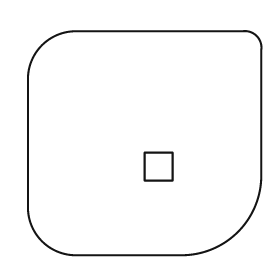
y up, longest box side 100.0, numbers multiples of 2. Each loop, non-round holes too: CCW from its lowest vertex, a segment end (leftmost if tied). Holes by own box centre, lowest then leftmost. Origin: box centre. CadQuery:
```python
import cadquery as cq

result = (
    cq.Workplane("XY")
    .moveTo(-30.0, -48.0)
    .lineTo(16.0, -48.0)
    .threePointArc((40.0, -38.0), (50.0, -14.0))
    .lineTo(50.0, 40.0)
    .threePointArc((48.0, 46.0), (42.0, 48.0))
    .lineTo(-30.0, 48.0)
    .threePointArc((-44.0, 42.0), (-50.0, 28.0))
    .lineTo(-50.0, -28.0)
    .threePointArc((-44.0, -42.0), (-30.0, -48.0))
    .close()
    .moveTo(0.0, -16.0)
    .lineTo(12.0, -16.0)
    .lineTo(12.0, -4.0)
    .lineTo(0.0, -4.0)
    .close()
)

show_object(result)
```